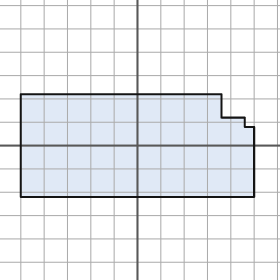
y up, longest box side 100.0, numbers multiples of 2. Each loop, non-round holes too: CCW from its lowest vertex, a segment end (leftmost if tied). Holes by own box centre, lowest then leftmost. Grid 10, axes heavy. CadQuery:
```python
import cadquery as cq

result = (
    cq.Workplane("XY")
    .moveTo(-50.0, -22.0)
    .lineTo(50.0, -22.0)
    .lineTo(50.0, 8.0)
    .lineTo(46.0, 8.0)
    .lineTo(46.0, 12.0)
    .lineTo(36.0, 12.0)
    .lineTo(36.0, 22.0)
    .lineTo(-50.0, 22.0)
    .close()
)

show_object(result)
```